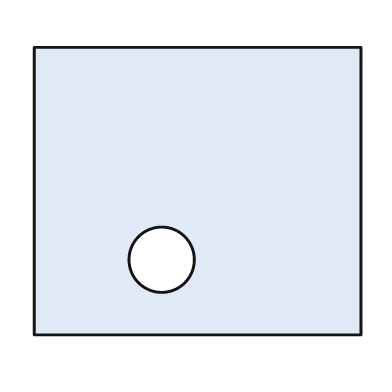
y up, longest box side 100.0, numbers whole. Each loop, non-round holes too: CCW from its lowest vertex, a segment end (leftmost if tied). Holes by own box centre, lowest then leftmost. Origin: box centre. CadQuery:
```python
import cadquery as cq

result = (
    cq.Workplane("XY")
    .moveTo(-50.0, -44.0)
    .lineTo(50.0, -44.0)
    .lineTo(50.0, 44.0)
    .lineTo(-50.0, 44.0)
    .close()
    .moveTo(-11.0, -21.0)
    .circle(10.0)
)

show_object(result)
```